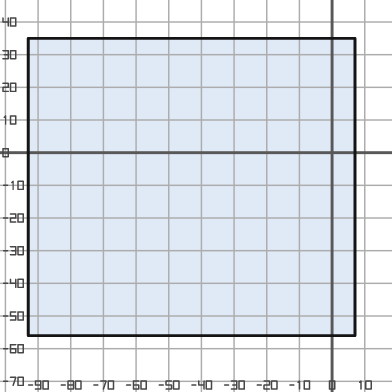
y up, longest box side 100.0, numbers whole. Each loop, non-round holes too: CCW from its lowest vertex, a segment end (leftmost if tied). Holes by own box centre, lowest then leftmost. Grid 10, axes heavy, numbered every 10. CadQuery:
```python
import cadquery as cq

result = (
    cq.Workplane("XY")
    .moveTo(-93.0, -56.0)
    .lineTo(7.0, -56.0)
    .lineTo(7.0, 35.0)
    .lineTo(-93.0, 35.0)
    .close()
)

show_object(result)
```